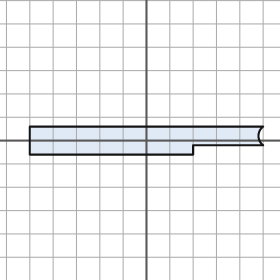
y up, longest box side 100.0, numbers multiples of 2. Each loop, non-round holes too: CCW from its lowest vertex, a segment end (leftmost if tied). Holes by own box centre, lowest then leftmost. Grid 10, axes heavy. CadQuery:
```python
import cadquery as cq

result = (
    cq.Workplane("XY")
    .moveTo(-50.0, -6.0)
    .lineTo(20.0, -6.0)
    .lineTo(20.0, -2.0)
    .lineTo(50.0, -2.0)
    .threePointArc((48.0, 2.0), (50.0, 6.0))
    .lineTo(-50.0, 6.0)
    .close()
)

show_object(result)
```